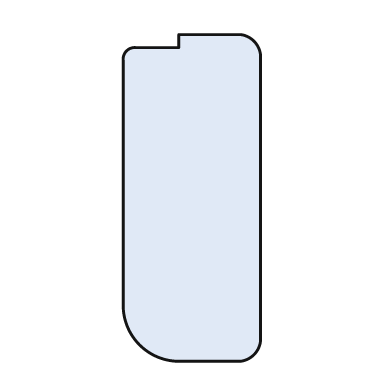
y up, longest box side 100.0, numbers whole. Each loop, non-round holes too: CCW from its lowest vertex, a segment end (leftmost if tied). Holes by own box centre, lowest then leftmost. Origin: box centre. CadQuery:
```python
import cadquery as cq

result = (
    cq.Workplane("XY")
    .moveTo(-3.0, -50.0)
    .lineTo(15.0, -50.0)
    .threePointArc((19.0, -48.0), (21.0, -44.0))
    .lineTo(21.0, 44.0)
    .threePointArc((19.0, 48.0), (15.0, 50.0))
    .lineTo(-4.0, 50.0)
    .lineTo(-4.0, 46.0)
    .lineTo(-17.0, 46.0)
    .threePointArc((-20.0, 45.0), (-21.0, 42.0))
    .lineTo(-21.0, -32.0)
    .threePointArc((-16.0, -45.0), (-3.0, -50.0))
    .close()
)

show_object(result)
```